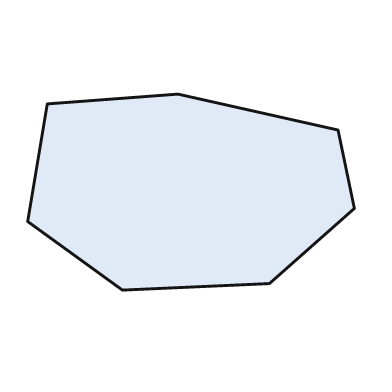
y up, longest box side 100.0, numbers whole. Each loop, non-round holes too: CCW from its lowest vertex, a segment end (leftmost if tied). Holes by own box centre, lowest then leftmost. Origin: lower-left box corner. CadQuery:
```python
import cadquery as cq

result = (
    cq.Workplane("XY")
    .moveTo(29.0, 0.0)
    .lineTo(74.0, 2.0)
    .lineTo(100.0, 25.0)
    .lineTo(95.0, 49.0)
    .lineTo(46.0, 60.0)
    .lineTo(6.0, 57.0)
    .lineTo(0.0, 21.0)
    .close()
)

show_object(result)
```